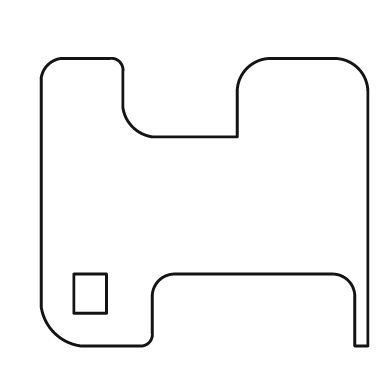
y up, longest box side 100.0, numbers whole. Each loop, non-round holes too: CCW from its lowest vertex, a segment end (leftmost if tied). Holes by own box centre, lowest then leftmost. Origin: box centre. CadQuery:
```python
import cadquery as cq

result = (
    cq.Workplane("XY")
    .moveTo(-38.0, -44.0)
    .lineTo(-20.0, -44.0)
    .threePointArc((-17.0, -43.0), (-16.0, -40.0))
    .lineTo(-16.0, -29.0)
    .threePointArc((-14.0, -24.0), (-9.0, -22.0))
    .lineTo(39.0, -22.0)
    .threePointArc((44.0, -24.0), (46.0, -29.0))
    .lineTo(46.0, -44.0)
    .lineTo(50.0, -44.0)
    .lineTo(50.0, 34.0)
    .threePointArc((47.0, 41.0), (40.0, 44.0))
    .lineTo(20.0, 44.0)
    .threePointArc((13.0, 41.0), (10.0, 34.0))
    .lineTo(10.0, 20.0)
    .lineTo(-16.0, 20.0)
    .threePointArc((-22.0, 23.0), (-25.0, 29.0))
    .lineTo(-25.0, 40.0)
    .threePointArc((-26.0, 43.0), (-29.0, 44.0))
    .lineTo(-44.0, 44.0)
    .threePointArc((-48.0, 42.0), (-50.0, 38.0))
    .lineTo(-50.0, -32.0)
    .threePointArc((-46.0, -40.0), (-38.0, -44.0))
    .close()
    .moveTo(-40.0, -34.0)
    .lineTo(-30.0, -34.0)
    .lineTo(-30.0, -22.0)
    .lineTo(-40.0, -22.0)
    .close()
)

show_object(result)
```